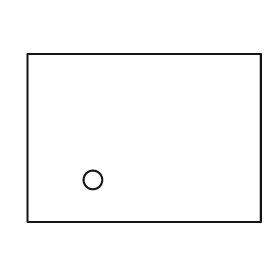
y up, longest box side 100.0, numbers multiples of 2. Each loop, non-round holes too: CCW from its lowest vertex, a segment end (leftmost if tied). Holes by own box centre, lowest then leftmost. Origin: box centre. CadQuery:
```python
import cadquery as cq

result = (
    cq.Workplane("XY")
    .moveTo(-50.0, -36.0)
    .lineTo(50.0, -36.0)
    .lineTo(50.0, 36.0)
    .lineTo(-50.0, 36.0)
    .close()
    .moveTo(-22.0, -18.0)
    .circle(4.0)
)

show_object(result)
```